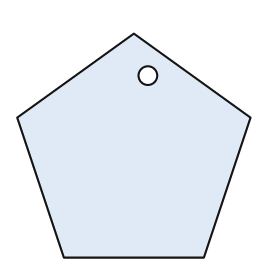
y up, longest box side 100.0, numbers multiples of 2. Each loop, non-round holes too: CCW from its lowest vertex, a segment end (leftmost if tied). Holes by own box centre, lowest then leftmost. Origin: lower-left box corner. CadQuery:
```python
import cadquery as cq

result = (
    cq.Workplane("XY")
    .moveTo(20.0, 0.0)
    .lineTo(80.0, 0.0)
    .lineTo(100.0, 60.0)
    .lineTo(50.0, 96.0)
    .lineTo(0.0, 60.0)
    .close()
    .moveTo(56.0, 78.0)
    .circle(4.0)
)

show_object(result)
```